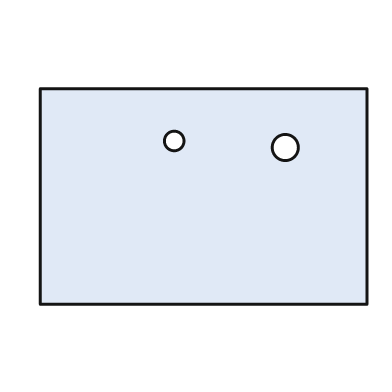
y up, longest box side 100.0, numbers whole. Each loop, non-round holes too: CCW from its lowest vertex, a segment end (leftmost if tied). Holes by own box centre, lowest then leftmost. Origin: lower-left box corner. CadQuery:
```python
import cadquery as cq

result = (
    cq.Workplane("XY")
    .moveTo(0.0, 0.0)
    .lineTo(100.0, 0.0)
    .lineTo(100.0, 66.0)
    .lineTo(0.0, 66.0)
    .close()
    .moveTo(75.0, 48.0)
    .circle(4.0)
    .moveTo(41.0, 50.0)
    .circle(3.0)
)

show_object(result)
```